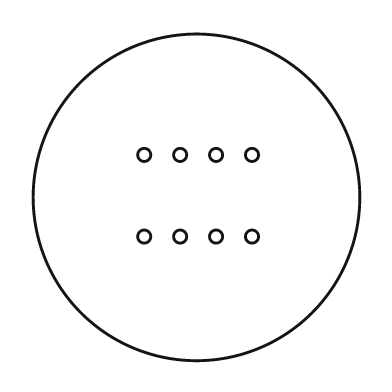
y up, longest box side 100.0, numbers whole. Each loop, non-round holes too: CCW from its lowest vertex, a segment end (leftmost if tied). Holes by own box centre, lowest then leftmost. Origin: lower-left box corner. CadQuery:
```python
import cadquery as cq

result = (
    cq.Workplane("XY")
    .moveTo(50.0, 50.0)
    .circle(50.0)
    .moveTo(34.0, 38.0)
    .circle(2.0)
    .moveTo(45.0, 38.0)
    .circle(2.0)
    .moveTo(56.0, 38.0)
    .circle(2.0)
    .moveTo(67.0, 38.0)
    .circle(2.0)
    .moveTo(34.0, 63.0)
    .circle(2.0)
    .moveTo(45.0, 63.0)
    .circle(2.0)
    .moveTo(56.0, 63.0)
    .circle(2.0)
    .moveTo(67.0, 63.0)
    .circle(2.0)
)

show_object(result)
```